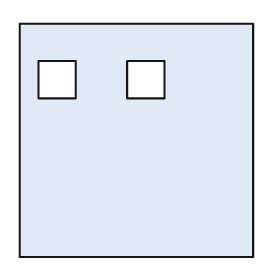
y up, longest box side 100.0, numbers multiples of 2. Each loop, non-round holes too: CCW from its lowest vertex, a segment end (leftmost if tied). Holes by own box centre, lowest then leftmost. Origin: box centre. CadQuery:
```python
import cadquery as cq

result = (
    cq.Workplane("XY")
    .moveTo(-50.0, -50.0)
    .lineTo(50.0, -50.0)
    .lineTo(50.0, 50.0)
    .lineTo(-50.0, 50.0)
    .close()
    .moveTo(-42.0, 18.0)
    .lineTo(-26.0, 18.0)
    .lineTo(-26.0, 34.0)
    .lineTo(-42.0, 34.0)
    .close()
    .moveTo(-4.0, 18.0)
    .lineTo(12.0, 18.0)
    .lineTo(12.0, 34.0)
    .lineTo(-4.0, 34.0)
    .close()
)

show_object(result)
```